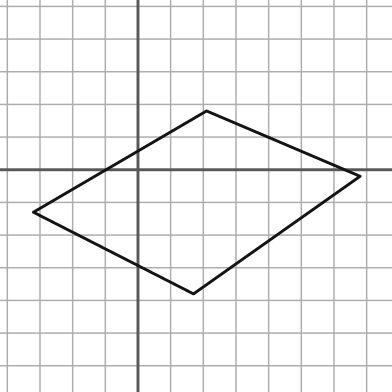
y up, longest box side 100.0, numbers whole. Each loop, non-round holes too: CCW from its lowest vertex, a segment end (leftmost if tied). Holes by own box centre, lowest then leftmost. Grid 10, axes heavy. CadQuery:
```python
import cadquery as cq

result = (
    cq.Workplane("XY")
    .moveTo(17.0, -38.0)
    .lineTo(68.0, -2.0)
    .lineTo(21.0, 18.0)
    .lineTo(-32.0, -13.0)
    .close()
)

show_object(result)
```